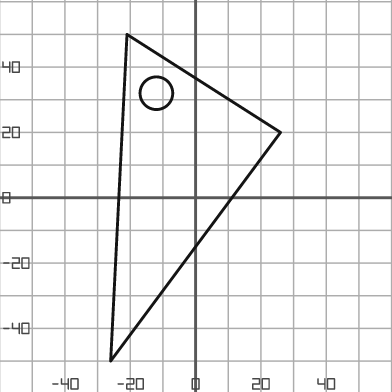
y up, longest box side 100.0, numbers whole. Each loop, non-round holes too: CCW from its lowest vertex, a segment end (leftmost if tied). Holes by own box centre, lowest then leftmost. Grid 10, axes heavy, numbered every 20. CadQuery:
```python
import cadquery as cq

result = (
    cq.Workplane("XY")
    .moveTo(-26.0, -50.0)
    .lineTo(26.0, 20.0)
    .lineTo(-21.0, 50.0)
    .close()
    .moveTo(-12.0, 32.0)
    .circle(5.0)
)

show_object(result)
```